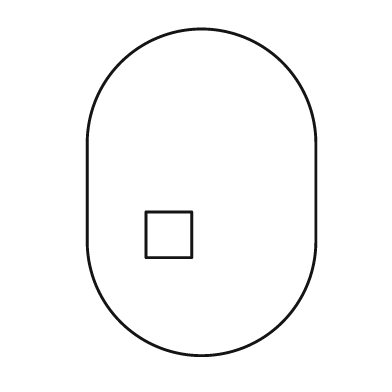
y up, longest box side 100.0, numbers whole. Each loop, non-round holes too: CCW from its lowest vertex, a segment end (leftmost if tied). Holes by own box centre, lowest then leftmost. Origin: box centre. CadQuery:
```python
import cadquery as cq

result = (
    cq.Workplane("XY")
    .moveTo(-35.0, -15.0)
    .threePointArc((0.0, -50.0), (35.0, -15.0))
    .lineTo(35.0, 15.0)
    .threePointArc((0.0, 50.0), (-35.0, 15.0))
    .close()
    .moveTo(-17.0, -20.0)
    .lineTo(-3.0, -20.0)
    .lineTo(-3.0, -6.0)
    .lineTo(-17.0, -6.0)
    .close()
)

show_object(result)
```